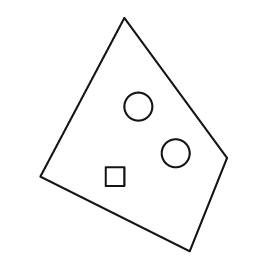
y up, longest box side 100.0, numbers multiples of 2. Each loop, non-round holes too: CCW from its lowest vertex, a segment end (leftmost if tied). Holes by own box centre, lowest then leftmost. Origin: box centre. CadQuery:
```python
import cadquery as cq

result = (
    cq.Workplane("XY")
    .moveTo(24.0, -50.0)
    .lineTo(40.0, -10.0)
    .lineTo(-4.0, 50.0)
    .lineTo(-40.0, -18.0)
    .close()
    .moveTo(-12.0, -22.0)
    .lineTo(-4.0, -22.0)
    .lineTo(-4.0, -14.0)
    .lineTo(-12.0, -14.0)
    .close()
    .moveTo(18.0, -8.0)
    .circle(6.0)
    .moveTo(2.0, 12.0)
    .circle(6.0)
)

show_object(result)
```